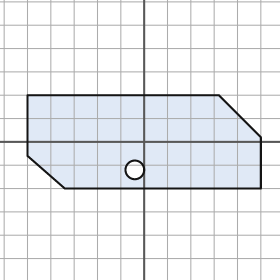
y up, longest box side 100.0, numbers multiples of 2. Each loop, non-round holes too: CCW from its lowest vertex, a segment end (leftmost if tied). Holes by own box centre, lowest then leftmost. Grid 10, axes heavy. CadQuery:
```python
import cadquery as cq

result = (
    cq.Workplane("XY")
    .moveTo(-34.0, -20.0)
    .lineTo(50.0, -20.0)
    .lineTo(50.0, 2.0)
    .lineTo(32.0, 20.0)
    .lineTo(-50.0, 20.0)
    .lineTo(-50.0, -6.0)
    .close()
    .moveTo(-4.0, -12.0)
    .circle(4.0)
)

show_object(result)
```